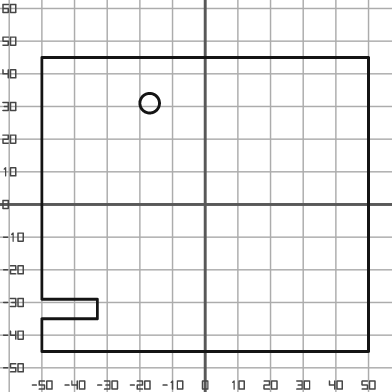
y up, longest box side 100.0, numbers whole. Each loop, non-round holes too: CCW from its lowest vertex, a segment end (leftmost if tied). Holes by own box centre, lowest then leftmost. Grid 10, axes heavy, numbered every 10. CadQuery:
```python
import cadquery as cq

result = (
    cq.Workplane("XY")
    .moveTo(-50.0, -45.0)
    .lineTo(50.0, -45.0)
    .lineTo(50.0, 45.0)
    .lineTo(-50.0, 45.0)
    .lineTo(-50.0, -29.0)
    .lineTo(-33.0, -29.0)
    .lineTo(-33.0, -35.0)
    .lineTo(-50.0, -35.0)
    .close()
    .moveTo(-17.0, 31.0)
    .circle(3.0)
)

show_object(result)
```